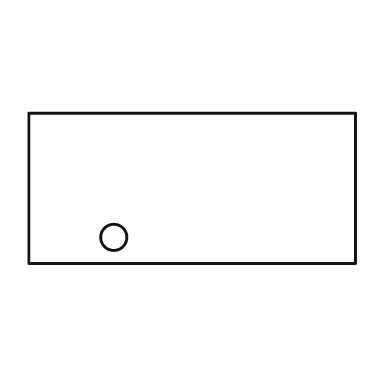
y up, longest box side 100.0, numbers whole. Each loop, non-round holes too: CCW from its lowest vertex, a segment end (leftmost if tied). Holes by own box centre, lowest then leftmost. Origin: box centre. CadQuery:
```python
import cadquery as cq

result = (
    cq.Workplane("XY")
    .moveTo(-50.0, -23.0)
    .lineTo(50.0, -23.0)
    .lineTo(50.0, 23.0)
    .lineTo(-50.0, 23.0)
    .close()
    .moveTo(-24.0, -15.0)
    .circle(4.0)
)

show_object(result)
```